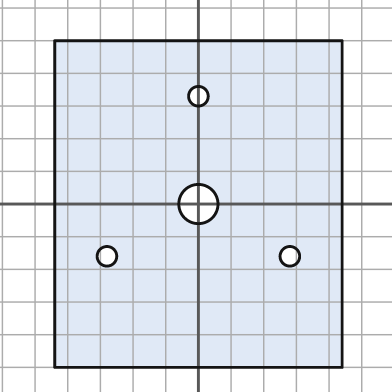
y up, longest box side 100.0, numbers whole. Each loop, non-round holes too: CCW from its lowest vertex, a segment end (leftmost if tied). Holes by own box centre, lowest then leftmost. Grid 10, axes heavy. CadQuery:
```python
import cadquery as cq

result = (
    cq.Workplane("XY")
    .moveTo(-44.0, -50.0)
    .lineTo(44.0, -50.0)
    .lineTo(44.0, 50.0)
    .lineTo(-44.0, 50.0)
    .close()
    .moveTo(-28.0, -16.0)
    .circle(3.0)
    .moveTo(28.0, -16.0)
    .circle(3.0)
    .moveTo(0.0, 0.0)
    .circle(6.0)
    .moveTo(0.0, 33.0)
    .circle(3.0)
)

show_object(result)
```